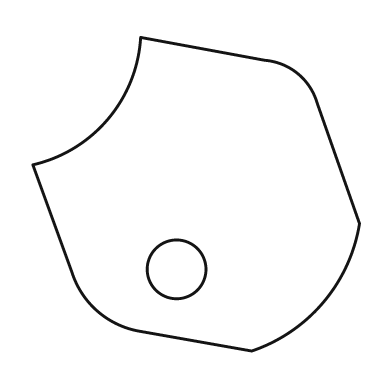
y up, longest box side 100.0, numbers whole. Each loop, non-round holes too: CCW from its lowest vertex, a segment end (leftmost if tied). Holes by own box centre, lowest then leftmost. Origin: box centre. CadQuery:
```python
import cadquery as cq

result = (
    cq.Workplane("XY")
    .moveTo(17.0, -48.0)
    .threePointArc((39.0, -33.0), (50.0, -9.0))
    .lineTo(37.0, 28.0)
    .threePointArc((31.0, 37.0), (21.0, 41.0))
    .lineTo(-17.0, 48.0)
    .threePointArc((-27.0, 23.0), (-50.0, 9.0))
    .lineTo(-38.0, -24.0)
    .threePointArc((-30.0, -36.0), (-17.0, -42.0))
    .close()
    .moveTo(-6.0, -23.0)
    .circle(9.0)
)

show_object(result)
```